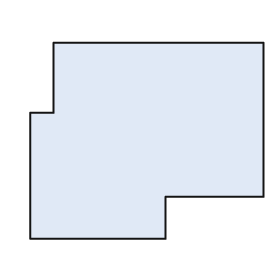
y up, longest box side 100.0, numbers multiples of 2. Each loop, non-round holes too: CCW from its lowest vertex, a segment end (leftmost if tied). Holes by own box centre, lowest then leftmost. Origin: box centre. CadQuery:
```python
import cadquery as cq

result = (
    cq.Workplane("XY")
    .moveTo(-50.0, -42.0)
    .lineTo(8.0, -42.0)
    .lineTo(8.0, -24.0)
    .lineTo(50.0, -24.0)
    .lineTo(50.0, 42.0)
    .lineTo(-40.0, 42.0)
    .lineTo(-40.0, 12.0)
    .lineTo(-50.0, 12.0)
    .close()
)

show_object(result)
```